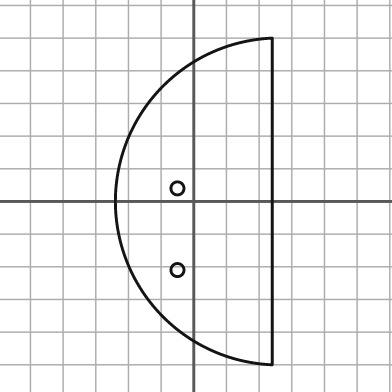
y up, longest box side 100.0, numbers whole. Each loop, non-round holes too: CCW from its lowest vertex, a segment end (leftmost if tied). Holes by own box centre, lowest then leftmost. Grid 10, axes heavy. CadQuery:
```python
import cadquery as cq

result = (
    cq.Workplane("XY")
    .moveTo(24.0, -50.0)
    .lineTo(24.0, 50.0)
    .threePointArc((-24.0, 0.0), (24.0, -50.0))
    .close()
    .moveTo(-5.0, -21.0)
    .circle(2.0)
    .moveTo(-5.0, 4.0)
    .circle(2.0)
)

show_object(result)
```